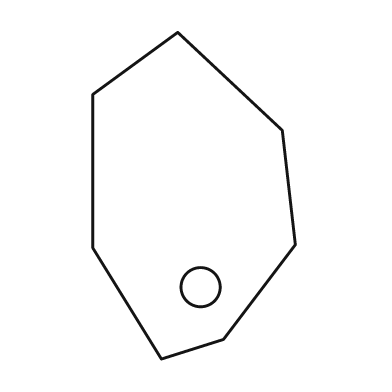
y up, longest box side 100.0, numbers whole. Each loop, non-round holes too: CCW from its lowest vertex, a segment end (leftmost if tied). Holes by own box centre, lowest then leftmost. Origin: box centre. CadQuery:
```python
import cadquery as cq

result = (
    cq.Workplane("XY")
    .moveTo(-10.0, -50.0)
    .lineTo(9.0, -44.0)
    .lineTo(31.0, -15.0)
    .lineTo(27.0, 20.0)
    .lineTo(-5.0, 50.0)
    .lineTo(-31.0, 31.0)
    .lineTo(-31.0, -16.0)
    .close()
    .moveTo(2.0, -28.0)
    .circle(6.0)
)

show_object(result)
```